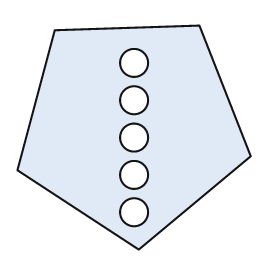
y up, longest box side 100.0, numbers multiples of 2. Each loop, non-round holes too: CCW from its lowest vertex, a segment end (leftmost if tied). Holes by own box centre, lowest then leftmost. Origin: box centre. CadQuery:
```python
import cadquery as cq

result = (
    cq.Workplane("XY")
    .moveTo(2.0, -48.0)
    .lineTo(50.0, -8.0)
    .lineTo(28.0, 48.0)
    .lineTo(-34.0, 46.0)
    .lineTo(-50.0, -14.0)
    .close()
    .moveTo(0.0, -32.0)
    .circle(6.0)
    .moveTo(0.0, -16.0)
    .circle(6.0)
    .moveTo(0.0, 0.0)
    .circle(6.0)
    .moveTo(0.0, 16.0)
    .circle(6.0)
    .moveTo(0.0, 32.0)
    .circle(6.0)
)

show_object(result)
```